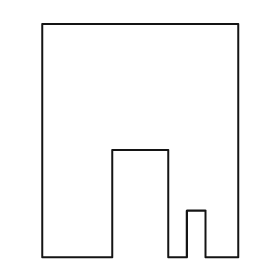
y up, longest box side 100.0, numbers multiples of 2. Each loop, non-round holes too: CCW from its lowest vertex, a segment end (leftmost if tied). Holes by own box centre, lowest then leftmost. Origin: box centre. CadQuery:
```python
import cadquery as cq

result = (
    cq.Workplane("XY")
    .moveTo(-42.0, -50.0)
    .lineTo(-12.0, -50.0)
    .lineTo(-12.0, -4.0)
    .lineTo(12.0, -4.0)
    .lineTo(12.0, -50.0)
    .lineTo(20.0, -50.0)
    .lineTo(20.0, -30.0)
    .lineTo(28.0, -30.0)
    .lineTo(28.0, -50.0)
    .lineTo(42.0, -50.0)
    .lineTo(42.0, 50.0)
    .lineTo(-42.0, 50.0)
    .close()
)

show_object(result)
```